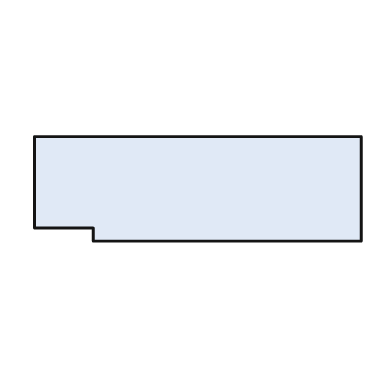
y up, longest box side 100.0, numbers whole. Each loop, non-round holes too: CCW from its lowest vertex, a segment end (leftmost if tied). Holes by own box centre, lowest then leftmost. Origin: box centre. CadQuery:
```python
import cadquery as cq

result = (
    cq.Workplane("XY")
    .moveTo(-32.0, -16.0)
    .lineTo(50.0, -16.0)
    .lineTo(50.0, 16.0)
    .lineTo(-50.0, 16.0)
    .lineTo(-50.0, -12.0)
    .lineTo(-32.0, -12.0)
    .close()
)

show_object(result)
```